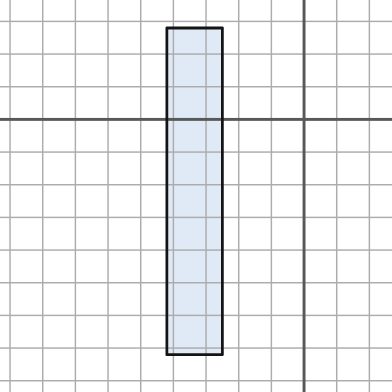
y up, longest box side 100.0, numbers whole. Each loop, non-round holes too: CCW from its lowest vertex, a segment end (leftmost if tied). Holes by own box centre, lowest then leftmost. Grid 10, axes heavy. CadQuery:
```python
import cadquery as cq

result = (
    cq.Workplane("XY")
    .moveTo(-42.0, -72.0)
    .lineTo(-25.0, -72.0)
    .lineTo(-25.0, 28.0)
    .lineTo(-42.0, 28.0)
    .close()
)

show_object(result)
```